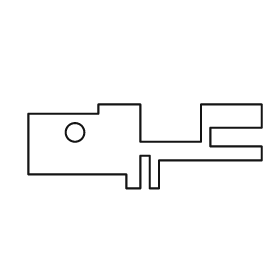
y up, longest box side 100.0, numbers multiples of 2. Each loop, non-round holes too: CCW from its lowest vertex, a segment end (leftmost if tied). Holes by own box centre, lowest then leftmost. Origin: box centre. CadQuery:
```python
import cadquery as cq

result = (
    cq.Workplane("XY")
    .moveTo(-8.0, -18.0)
    .lineTo(-2.0, -18.0)
    .lineTo(-2.0, -4.0)
    .lineTo(2.0, -4.0)
    .lineTo(2.0, -18.0)
    .lineTo(6.0, -18.0)
    .lineTo(6.0, -6.0)
    .lineTo(50.0, -6.0)
    .lineTo(50.0, 0.0)
    .lineTo(28.0, 0.0)
    .lineTo(28.0, 8.0)
    .lineTo(50.0, 8.0)
    .lineTo(50.0, 18.0)
    .lineTo(24.0, 18.0)
    .lineTo(24.0, 2.0)
    .lineTo(-2.0, 2.0)
    .lineTo(-2.0, 18.0)
    .lineTo(-20.0, 18.0)
    .lineTo(-20.0, 14.0)
    .lineTo(-50.0, 14.0)
    .lineTo(-50.0, -12.0)
    .lineTo(-8.0, -12.0)
    .close()
    .moveTo(-30.0, 6.0)
    .circle(4.0)
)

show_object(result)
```